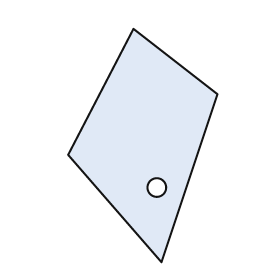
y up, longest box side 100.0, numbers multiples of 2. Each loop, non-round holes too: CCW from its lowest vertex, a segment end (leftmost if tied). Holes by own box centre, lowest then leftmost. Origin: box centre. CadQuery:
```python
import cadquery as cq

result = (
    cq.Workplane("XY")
    .moveTo(8.0, -50.0)
    .lineTo(32.0, 22.0)
    .lineTo(-4.0, 50.0)
    .lineTo(-32.0, -4.0)
    .close()
    .moveTo(6.0, -18.0)
    .circle(4.0)
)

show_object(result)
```